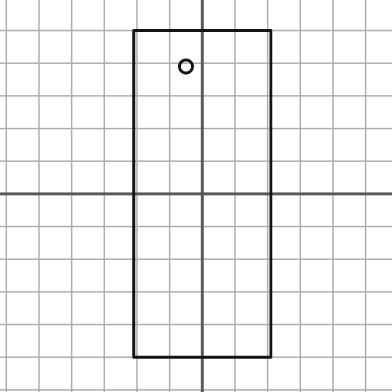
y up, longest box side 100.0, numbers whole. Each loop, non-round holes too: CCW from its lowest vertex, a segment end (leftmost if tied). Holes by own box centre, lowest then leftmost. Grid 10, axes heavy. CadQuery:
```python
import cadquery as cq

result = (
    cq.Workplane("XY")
    .moveTo(-21.0, -50.0)
    .lineTo(21.0, -50.0)
    .lineTo(21.0, 50.0)
    .lineTo(-21.0, 50.0)
    .close()
    .moveTo(-5.0, 39.0)
    .circle(2.0)
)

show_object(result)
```